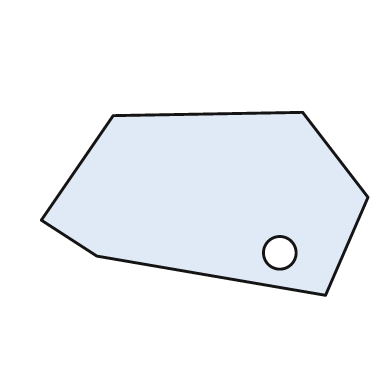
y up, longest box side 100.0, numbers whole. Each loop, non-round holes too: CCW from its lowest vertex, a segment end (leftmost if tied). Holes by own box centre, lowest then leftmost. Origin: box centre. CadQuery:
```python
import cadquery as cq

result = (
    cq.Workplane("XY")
    .moveTo(37.0, -28.0)
    .lineTo(50.0, 2.0)
    .lineTo(30.0, 28.0)
    .lineTo(-28.0, 27.0)
    .lineTo(-50.0, -5.0)
    .lineTo(-33.0, -16.0)
    .close()
    .moveTo(23.0, -15.0)
    .circle(5.0)
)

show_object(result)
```